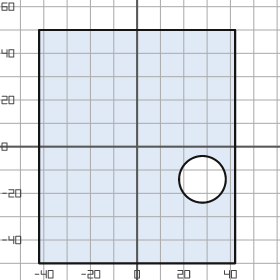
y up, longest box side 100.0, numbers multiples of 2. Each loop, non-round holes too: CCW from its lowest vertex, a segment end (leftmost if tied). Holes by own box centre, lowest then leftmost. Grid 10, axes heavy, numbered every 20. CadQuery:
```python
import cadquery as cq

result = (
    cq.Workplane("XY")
    .moveTo(-42.0, -50.0)
    .lineTo(42.0, -50.0)
    .lineTo(42.0, 50.0)
    .lineTo(-42.0, 50.0)
    .close()
    .moveTo(28.0, -14.0)
    .circle(10.0)
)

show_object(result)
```